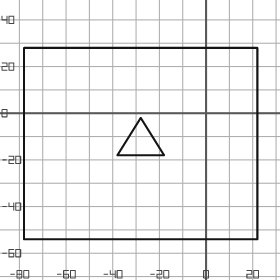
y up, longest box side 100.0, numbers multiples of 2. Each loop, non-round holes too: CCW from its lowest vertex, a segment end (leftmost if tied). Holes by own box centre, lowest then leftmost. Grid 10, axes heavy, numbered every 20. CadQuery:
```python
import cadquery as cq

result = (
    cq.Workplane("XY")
    .moveTo(-78.0, -54.0)
    .lineTo(22.0, -54.0)
    .lineTo(22.0, 28.0)
    .lineTo(-78.0, 28.0)
    .close()
    .moveTo(-38.0, -18.0)
    .lineTo(-18.0, -18.0)
    .lineTo(-28.0, -2.0)
    .close()
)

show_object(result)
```